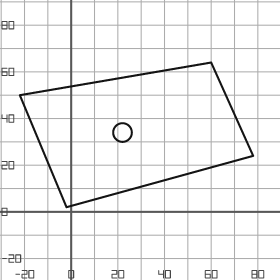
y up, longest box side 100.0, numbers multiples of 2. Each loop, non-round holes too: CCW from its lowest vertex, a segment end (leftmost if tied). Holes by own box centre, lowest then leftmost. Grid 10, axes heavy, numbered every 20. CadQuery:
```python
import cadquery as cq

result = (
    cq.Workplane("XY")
    .moveTo(-2.0, 2.0)
    .lineTo(78.0, 24.0)
    .lineTo(60.0, 64.0)
    .lineTo(-22.0, 50.0)
    .close()
    .moveTo(22.0, 34.0)
    .circle(4.0)
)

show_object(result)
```